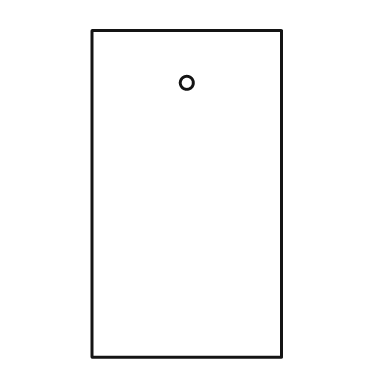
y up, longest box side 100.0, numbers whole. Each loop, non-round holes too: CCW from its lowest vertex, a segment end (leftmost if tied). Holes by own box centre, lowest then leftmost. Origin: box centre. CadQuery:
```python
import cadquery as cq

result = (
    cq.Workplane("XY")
    .moveTo(-29.0, -50.0)
    .lineTo(29.0, -50.0)
    .lineTo(29.0, 50.0)
    .lineTo(-29.0, 50.0)
    .close()
    .moveTo(0.0, 34.0)
    .circle(2.0)
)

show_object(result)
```